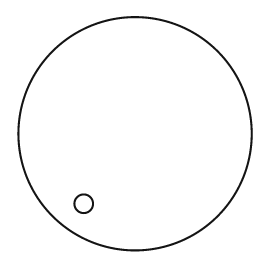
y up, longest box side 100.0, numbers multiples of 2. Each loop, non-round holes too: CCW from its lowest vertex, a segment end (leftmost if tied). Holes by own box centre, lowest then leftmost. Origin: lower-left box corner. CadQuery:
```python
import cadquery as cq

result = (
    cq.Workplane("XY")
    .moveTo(50.0, 50.0)
    .circle(50.0)
    .moveTo(28.0, 20.0)
    .circle(4.0)
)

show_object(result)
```